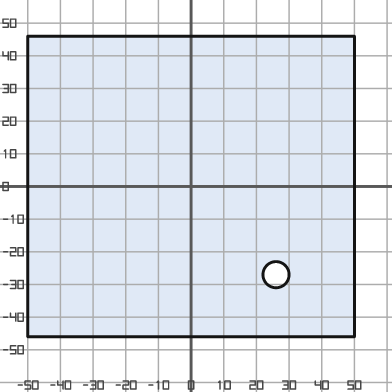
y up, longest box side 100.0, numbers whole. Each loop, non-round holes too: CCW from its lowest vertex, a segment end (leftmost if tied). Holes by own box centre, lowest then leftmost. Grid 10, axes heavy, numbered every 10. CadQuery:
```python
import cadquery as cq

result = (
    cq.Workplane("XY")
    .moveTo(-50.0, -46.0)
    .lineTo(50.0, -46.0)
    .lineTo(50.0, 46.0)
    .lineTo(-50.0, 46.0)
    .close()
    .moveTo(26.0, -27.0)
    .circle(4.0)
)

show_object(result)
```